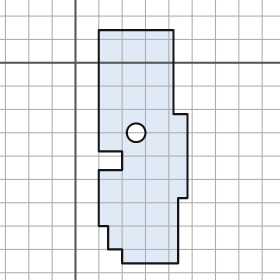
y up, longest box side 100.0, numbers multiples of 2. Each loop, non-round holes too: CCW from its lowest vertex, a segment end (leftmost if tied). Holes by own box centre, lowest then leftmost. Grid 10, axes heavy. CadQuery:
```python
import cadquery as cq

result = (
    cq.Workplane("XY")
    .moveTo(20.0, -86.0)
    .lineTo(44.0, -86.0)
    .lineTo(44.0, -58.0)
    .lineTo(48.0, -58.0)
    .lineTo(48.0, -22.0)
    .lineTo(42.0, -22.0)
    .lineTo(42.0, 14.0)
    .lineTo(10.0, 14.0)
    .lineTo(10.0, -38.0)
    .lineTo(20.0, -38.0)
    .lineTo(20.0, -46.0)
    .lineTo(10.0, -46.0)
    .lineTo(10.0, -70.0)
    .lineTo(14.0, -70.0)
    .lineTo(14.0, -80.0)
    .lineTo(20.0, -80.0)
    .close()
    .moveTo(26.0, -30.0)
    .circle(4.0)
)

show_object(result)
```